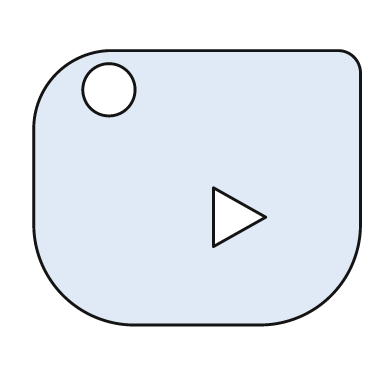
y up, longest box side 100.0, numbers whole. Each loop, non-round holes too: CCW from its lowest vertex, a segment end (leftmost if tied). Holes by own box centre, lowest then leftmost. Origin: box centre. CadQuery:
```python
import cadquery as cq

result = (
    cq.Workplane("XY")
    .moveTo(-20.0, -42.0)
    .lineTo(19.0, -42.0)
    .threePointArc((41.0, -33.0), (50.0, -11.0))
    .lineTo(50.0, 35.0)
    .threePointArc((48.0, 40.0), (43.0, 42.0))
    .lineTo(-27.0, 42.0)
    .threePointArc((-43.0, 35.0), (-50.0, 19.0))
    .lineTo(-50.0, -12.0)
    .threePointArc((-41.0, -33.0), (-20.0, -42.0))
    .close()
    .moveTo(5.0, -18.0)
    .lineTo(21.0, -9.0)
    .lineTo(5.0, 0.0)
    .close()
    .moveTo(-27.0, 30.0)
    .circle(8.0)
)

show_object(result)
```